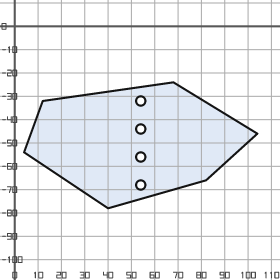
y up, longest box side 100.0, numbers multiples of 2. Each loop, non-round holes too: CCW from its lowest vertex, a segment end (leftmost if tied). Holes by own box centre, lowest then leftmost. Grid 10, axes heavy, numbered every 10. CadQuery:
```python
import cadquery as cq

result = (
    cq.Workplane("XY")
    .moveTo(40.0, -78.0)
    .lineTo(82.0, -66.0)
    .lineTo(104.0, -46.0)
    .lineTo(68.0, -24.0)
    .lineTo(12.0, -32.0)
    .lineTo(4.0, -54.0)
    .close()
    .moveTo(54.0, -68.0)
    .circle(2.0)
    .moveTo(54.0, -56.0)
    .circle(2.0)
    .moveTo(54.0, -44.0)
    .circle(2.0)
    .moveTo(54.0, -32.0)
    .circle(2.0)
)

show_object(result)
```